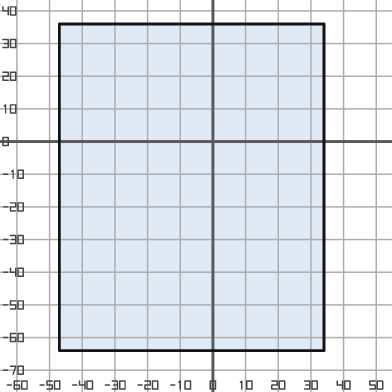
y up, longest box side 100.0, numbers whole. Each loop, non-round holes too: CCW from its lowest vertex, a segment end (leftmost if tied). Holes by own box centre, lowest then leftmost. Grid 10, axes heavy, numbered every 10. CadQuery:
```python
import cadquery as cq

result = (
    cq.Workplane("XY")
    .moveTo(-47.0, -64.0)
    .lineTo(34.0, -64.0)
    .lineTo(34.0, 36.0)
    .lineTo(-47.0, 36.0)
    .close()
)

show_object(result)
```